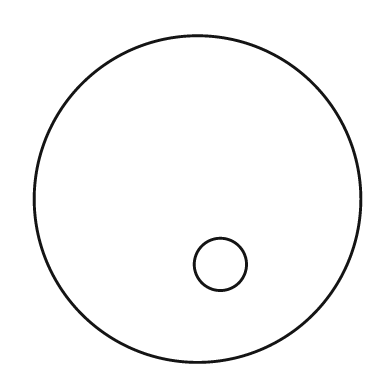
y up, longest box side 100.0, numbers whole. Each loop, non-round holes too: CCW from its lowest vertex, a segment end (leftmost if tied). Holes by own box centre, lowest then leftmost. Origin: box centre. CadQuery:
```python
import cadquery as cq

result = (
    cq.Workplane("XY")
    .moveTo(0.0, 0.0)
    .circle(50.0)
    .moveTo(7.0, -20.0)
    .circle(8.0)
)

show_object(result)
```